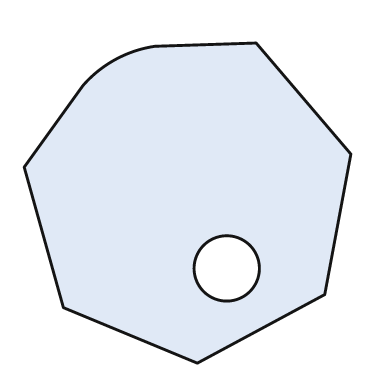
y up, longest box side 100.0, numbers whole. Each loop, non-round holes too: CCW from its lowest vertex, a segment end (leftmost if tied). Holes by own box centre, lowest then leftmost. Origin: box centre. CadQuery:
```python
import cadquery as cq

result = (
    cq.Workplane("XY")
    .moveTo(3.0, -49.0)
    .lineTo(42.0, -28.0)
    .lineTo(50.0, 15.0)
    .lineTo(21.0, 49.0)
    .lineTo(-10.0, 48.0)
    .threePointArc((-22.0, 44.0), (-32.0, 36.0))
    .lineTo(-50.0, 11.0)
    .lineTo(-38.0, -32.0)
    .close()
    .moveTo(12.0, -20.0)
    .circle(10.0)
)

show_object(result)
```